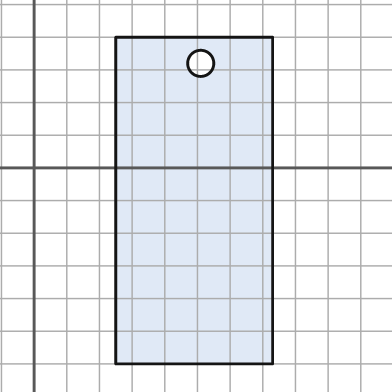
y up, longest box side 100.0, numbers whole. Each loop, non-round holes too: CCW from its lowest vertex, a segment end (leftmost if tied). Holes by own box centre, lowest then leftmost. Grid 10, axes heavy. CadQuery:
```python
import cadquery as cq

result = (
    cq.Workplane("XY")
    .moveTo(25.0, -60.0)
    .lineTo(73.0, -60.0)
    .lineTo(73.0, 40.0)
    .lineTo(25.0, 40.0)
    .close()
    .moveTo(51.0, 32.0)
    .circle(4.0)
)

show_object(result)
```